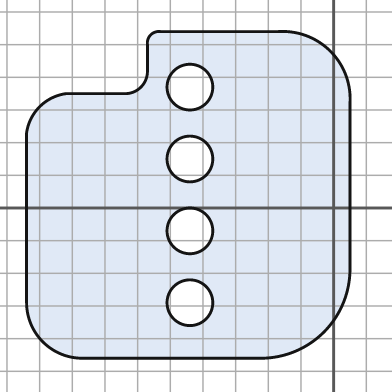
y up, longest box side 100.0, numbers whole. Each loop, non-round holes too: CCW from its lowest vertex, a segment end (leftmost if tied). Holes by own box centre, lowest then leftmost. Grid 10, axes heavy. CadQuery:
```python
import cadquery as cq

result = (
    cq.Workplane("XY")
    .moveTo(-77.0, -46.0)
    .lineTo(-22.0, -46.0)
    .threePointArc((-3.0, -38.0), (5.0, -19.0))
    .lineTo(5.0, 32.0)
    .threePointArc((-1.0, 48.0), (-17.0, 54.0))
    .lineTo(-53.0, 54.0)
    .threePointArc((-56.0, 53.0), (-57.0, 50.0))
    .lineTo(-57.0, 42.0)
    .threePointArc((-59.0, 37.0), (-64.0, 35.0))
    .lineTo(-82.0, 35.0)
    .threePointArc((-90.0, 31.0), (-94.0, 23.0))
    .lineTo(-94.0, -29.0)
    .threePointArc((-89.0, -41.0), (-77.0, -46.0))
    .close()
    .moveTo(-44.0, -29.0)
    .circle(7.0)
    .moveTo(-44.0, -7.0)
    .circle(7.0)
    .moveTo(-44.0, 15.0)
    .circle(7.0)
    .moveTo(-44.0, 37.0)
    .circle(7.0)
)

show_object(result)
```